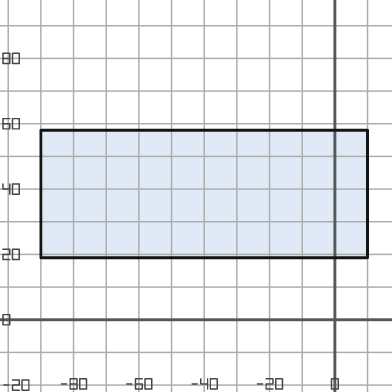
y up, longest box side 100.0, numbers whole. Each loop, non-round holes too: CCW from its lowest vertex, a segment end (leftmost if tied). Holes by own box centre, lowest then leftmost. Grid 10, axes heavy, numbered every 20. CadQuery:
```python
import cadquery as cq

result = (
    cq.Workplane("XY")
    .moveTo(-90.0, 19.0)
    .lineTo(10.0, 19.0)
    .lineTo(10.0, 58.0)
    .lineTo(-90.0, 58.0)
    .close()
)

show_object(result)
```